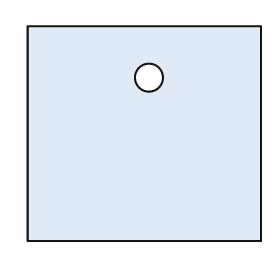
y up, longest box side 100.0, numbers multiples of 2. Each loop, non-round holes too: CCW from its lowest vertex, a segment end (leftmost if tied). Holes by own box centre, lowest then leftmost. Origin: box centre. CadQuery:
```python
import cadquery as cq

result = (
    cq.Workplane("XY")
    .moveTo(-50.0, -46.0)
    .lineTo(50.0, -46.0)
    .lineTo(50.0, 46.0)
    .lineTo(-50.0, 46.0)
    .close()
    .moveTo(2.0, 24.0)
    .circle(6.0)
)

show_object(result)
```